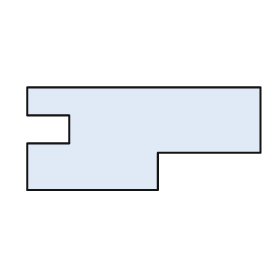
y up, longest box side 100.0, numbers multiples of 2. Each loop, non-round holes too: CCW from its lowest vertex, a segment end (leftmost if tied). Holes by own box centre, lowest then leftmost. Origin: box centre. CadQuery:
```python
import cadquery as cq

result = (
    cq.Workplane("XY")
    .moveTo(-50.0, -22.0)
    .lineTo(6.0, -22.0)
    .lineTo(6.0, -6.0)
    .lineTo(50.0, -6.0)
    .lineTo(50.0, 22.0)
    .lineTo(-50.0, 22.0)
    .lineTo(-50.0, 10.0)
    .lineTo(-32.0, 10.0)
    .lineTo(-32.0, -2.0)
    .lineTo(-50.0, -2.0)
    .close()
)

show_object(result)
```